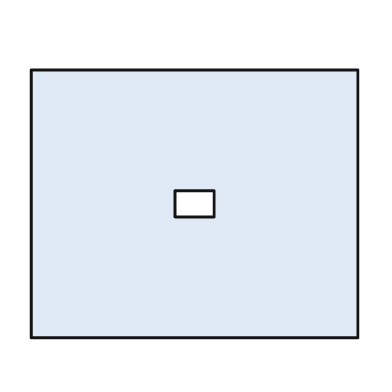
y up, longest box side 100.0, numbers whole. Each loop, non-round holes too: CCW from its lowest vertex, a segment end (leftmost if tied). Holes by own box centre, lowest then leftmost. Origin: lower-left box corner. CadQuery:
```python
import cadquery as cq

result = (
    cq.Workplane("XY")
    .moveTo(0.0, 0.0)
    .lineTo(100.0, 0.0)
    .lineTo(100.0, 82.0)
    .lineTo(0.0, 82.0)
    .close()
    .moveTo(44.0, 37.0)
    .lineTo(56.0, 37.0)
    .lineTo(56.0, 45.0)
    .lineTo(44.0, 45.0)
    .close()
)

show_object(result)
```